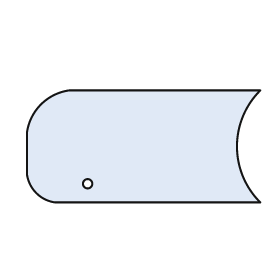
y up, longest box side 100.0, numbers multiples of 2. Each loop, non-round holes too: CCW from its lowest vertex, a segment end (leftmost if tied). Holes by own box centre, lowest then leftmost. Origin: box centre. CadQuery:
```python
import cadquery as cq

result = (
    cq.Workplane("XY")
    .moveTo(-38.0, -24.0)
    .lineTo(50.0, -24.0)
    .threePointArc((40.0, 0.0), (50.0, 24.0))
    .lineTo(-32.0, 24.0)
    .threePointArc((-44.0, 18.0), (-50.0, 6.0))
    .lineTo(-50.0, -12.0)
    .threePointArc((-46.0, -20.0), (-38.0, -24.0))
    .close()
    .moveTo(-24.0, -16.0)
    .circle(2.0)
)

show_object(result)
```